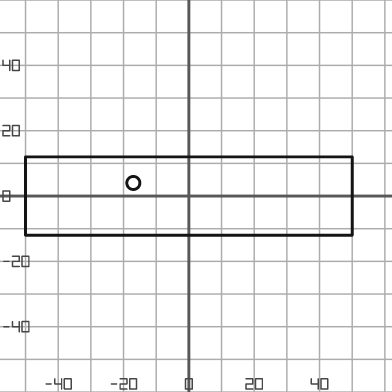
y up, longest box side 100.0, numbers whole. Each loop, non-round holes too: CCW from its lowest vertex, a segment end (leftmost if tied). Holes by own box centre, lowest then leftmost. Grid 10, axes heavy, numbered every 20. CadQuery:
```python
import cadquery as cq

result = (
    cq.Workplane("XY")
    .moveTo(-50.0, -12.0)
    .lineTo(50.0, -12.0)
    .lineTo(50.0, 12.0)
    .lineTo(-50.0, 12.0)
    .close()
    .moveTo(-17.0, 4.0)
    .circle(2.0)
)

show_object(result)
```